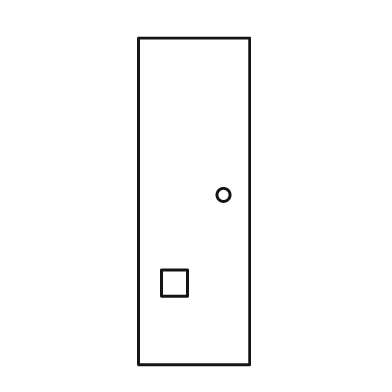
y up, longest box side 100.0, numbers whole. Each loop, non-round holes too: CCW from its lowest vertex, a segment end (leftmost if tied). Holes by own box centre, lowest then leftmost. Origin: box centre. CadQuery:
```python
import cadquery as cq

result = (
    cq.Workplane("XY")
    .moveTo(-17.0, -50.0)
    .lineTo(17.0, -50.0)
    .lineTo(17.0, 50.0)
    .lineTo(-17.0, 50.0)
    .close()
    .moveTo(-10.0, -29.0)
    .lineTo(-2.0, -29.0)
    .lineTo(-2.0, -21.0)
    .lineTo(-10.0, -21.0)
    .close()
    .moveTo(9.0, 2.0)
    .circle(2.0)
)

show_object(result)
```